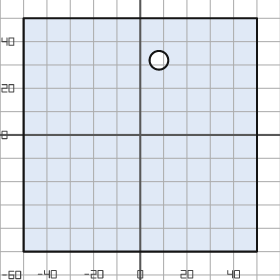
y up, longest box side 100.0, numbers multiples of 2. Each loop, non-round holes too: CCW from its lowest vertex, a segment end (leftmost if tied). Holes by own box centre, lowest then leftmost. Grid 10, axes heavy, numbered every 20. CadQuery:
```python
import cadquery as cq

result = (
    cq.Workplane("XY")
    .moveTo(-50.0, -50.0)
    .lineTo(50.0, -50.0)
    .lineTo(50.0, 50.0)
    .lineTo(-50.0, 50.0)
    .close()
    .moveTo(8.0, 32.0)
    .circle(4.0)
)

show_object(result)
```